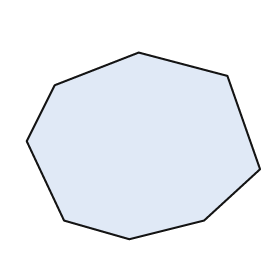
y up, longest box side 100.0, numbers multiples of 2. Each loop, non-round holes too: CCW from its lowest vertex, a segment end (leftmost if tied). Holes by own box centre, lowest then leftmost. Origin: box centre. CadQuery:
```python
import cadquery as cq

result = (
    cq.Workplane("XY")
    .moveTo(-6.0, -40.0)
    .lineTo(26.0, -32.0)
    .lineTo(50.0, -10.0)
    .lineTo(36.0, 30.0)
    .lineTo(-2.0, 40.0)
    .lineTo(-38.0, 26.0)
    .lineTo(-50.0, 2.0)
    .lineTo(-34.0, -32.0)
    .close()
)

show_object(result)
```